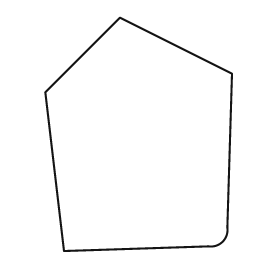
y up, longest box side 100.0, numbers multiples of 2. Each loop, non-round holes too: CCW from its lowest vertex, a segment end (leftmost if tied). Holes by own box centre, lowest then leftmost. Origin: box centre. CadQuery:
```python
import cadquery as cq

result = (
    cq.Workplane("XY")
    .moveTo(-32.0, -50.0)
    .lineTo(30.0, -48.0)
    .threePointArc((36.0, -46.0), (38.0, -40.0))
    .lineTo(40.0, 26.0)
    .lineTo(-8.0, 50.0)
    .lineTo(-40.0, 18.0)
    .close()
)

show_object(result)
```